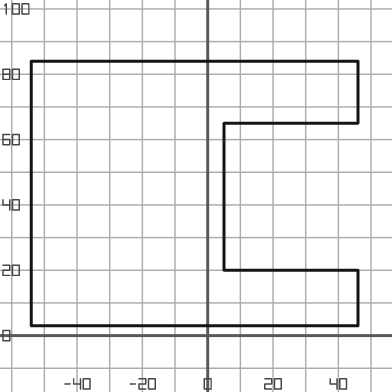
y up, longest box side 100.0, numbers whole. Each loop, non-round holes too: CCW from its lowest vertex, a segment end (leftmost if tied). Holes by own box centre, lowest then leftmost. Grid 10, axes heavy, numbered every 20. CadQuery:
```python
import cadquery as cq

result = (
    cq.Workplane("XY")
    .moveTo(-54.0, 3.0)
    .lineTo(46.0, 3.0)
    .lineTo(46.0, 20.0)
    .lineTo(5.0, 20.0)
    .lineTo(5.0, 65.0)
    .lineTo(46.0, 65.0)
    .lineTo(46.0, 84.0)
    .lineTo(-54.0, 84.0)
    .close()
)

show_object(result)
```